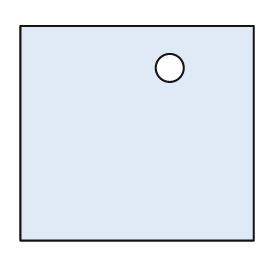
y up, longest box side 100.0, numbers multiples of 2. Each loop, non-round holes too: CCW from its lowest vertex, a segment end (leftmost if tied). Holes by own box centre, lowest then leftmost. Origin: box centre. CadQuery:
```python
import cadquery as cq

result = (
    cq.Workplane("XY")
    .moveTo(-50.0, -46.0)
    .lineTo(50.0, -46.0)
    .lineTo(50.0, 46.0)
    .lineTo(-50.0, 46.0)
    .close()
    .moveTo(14.0, 28.0)
    .circle(6.0)
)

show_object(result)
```